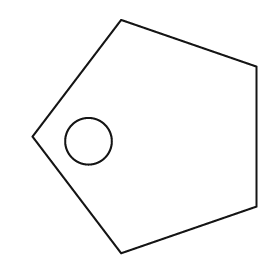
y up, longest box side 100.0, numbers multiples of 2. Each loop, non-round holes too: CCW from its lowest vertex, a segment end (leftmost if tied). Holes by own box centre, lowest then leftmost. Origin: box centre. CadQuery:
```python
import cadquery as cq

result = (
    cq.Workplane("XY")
    .moveTo(-10.0, -50.0)
    .lineTo(48.0, -30.0)
    .lineTo(48.0, 30.0)
    .lineTo(-10.0, 50.0)
    .lineTo(-48.0, 0.0)
    .close()
    .moveTo(-24.0, -2.0)
    .circle(10.0)
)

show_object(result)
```